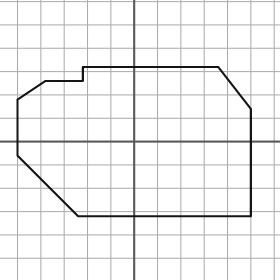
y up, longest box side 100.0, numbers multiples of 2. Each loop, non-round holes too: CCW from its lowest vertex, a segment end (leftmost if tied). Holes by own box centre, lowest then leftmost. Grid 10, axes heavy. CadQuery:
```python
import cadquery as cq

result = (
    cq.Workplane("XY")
    .moveTo(-24.0, -32.0)
    .lineTo(50.0, -32.0)
    .lineTo(50.0, 14.0)
    .lineTo(36.0, 32.0)
    .lineTo(-22.0, 32.0)
    .lineTo(-22.0, 26.0)
    .lineTo(-38.0, 26.0)
    .lineTo(-50.0, 18.0)
    .lineTo(-50.0, -6.0)
    .close()
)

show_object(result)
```